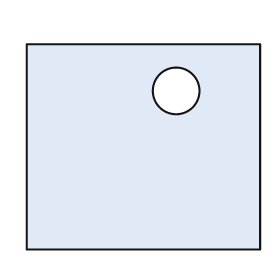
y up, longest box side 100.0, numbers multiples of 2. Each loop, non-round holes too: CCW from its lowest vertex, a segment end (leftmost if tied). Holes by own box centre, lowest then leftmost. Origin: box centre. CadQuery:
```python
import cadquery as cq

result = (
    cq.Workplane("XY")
    .moveTo(-50.0, -44.0)
    .lineTo(50.0, -44.0)
    .lineTo(50.0, 44.0)
    .lineTo(-50.0, 44.0)
    .close()
    .moveTo(14.0, 24.0)
    .circle(10.0)
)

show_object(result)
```